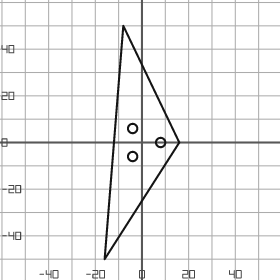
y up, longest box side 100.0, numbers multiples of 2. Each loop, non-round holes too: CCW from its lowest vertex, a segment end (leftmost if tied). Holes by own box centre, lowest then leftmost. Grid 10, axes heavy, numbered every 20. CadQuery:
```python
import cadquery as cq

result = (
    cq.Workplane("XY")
    .moveTo(-16.0, -50.0)
    .lineTo(16.0, 0.0)
    .lineTo(-8.0, 50.0)
    .close()
    .moveTo(-4.0, -6.0)
    .circle(2.0)
    .moveTo(8.0, 0.0)
    .circle(2.0)
    .moveTo(-4.0, 6.0)
    .circle(2.0)
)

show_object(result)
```